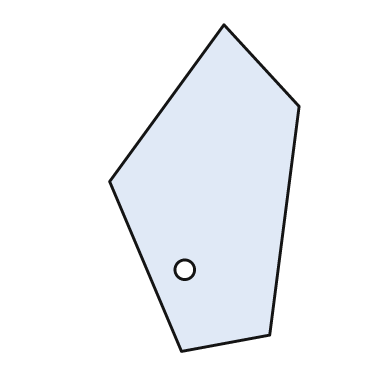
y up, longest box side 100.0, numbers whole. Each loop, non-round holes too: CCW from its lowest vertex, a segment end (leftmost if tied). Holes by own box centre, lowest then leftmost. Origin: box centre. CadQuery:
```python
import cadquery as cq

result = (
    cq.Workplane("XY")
    .moveTo(-7.0, -50.0)
    .lineTo(20.0, -45.0)
    .lineTo(29.0, 25.0)
    .lineTo(6.0, 50.0)
    .lineTo(-29.0, 2.0)
    .close()
    .moveTo(-6.0, -25.0)
    .circle(3.0)
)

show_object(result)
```